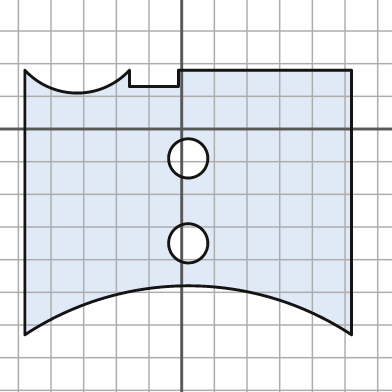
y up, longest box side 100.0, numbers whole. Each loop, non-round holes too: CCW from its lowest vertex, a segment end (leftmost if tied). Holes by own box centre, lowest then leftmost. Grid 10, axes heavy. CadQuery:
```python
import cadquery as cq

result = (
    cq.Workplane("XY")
    .moveTo(-48.0, -63.0)
    .threePointArc((2.0, -48.0), (52.0, -63.0))
    .lineTo(52.0, 18.0)
    .lineTo(-1.0, 18.0)
    .lineTo(-1.0, 13.0)
    .lineTo(-16.0, 13.0)
    .lineTo(-16.0, 18.0)
    .threePointArc((-32.0, 11.0), (-48.0, 18.0))
    .close()
    .moveTo(2.0, -35.0)
    .circle(6.0)
    .moveTo(2.0, -9.0)
    .circle(6.0)
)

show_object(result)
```